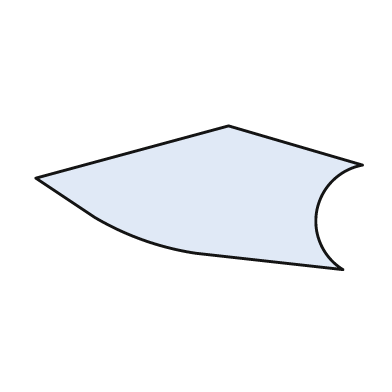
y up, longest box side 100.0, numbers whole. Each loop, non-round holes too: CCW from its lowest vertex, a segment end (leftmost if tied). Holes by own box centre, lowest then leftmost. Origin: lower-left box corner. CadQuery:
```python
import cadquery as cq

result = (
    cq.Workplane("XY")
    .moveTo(94.0, 0.0)
    .threePointArc((86.0, 18.0), (100.0, 32.0))
    .lineTo(59.0, 44.0)
    .lineTo(0.0, 28.0)
    .lineTo(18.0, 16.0)
    .threePointArc((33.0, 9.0), (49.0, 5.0))
    .close()
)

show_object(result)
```